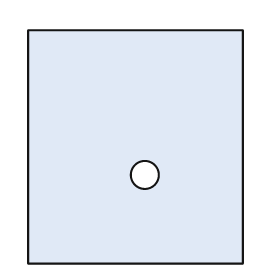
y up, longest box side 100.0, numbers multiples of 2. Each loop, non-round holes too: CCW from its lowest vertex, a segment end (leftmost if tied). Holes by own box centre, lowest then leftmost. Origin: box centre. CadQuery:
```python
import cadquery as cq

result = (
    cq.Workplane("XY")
    .moveTo(-46.0, -50.0)
    .lineTo(46.0, -50.0)
    .lineTo(46.0, 50.0)
    .lineTo(-46.0, 50.0)
    .close()
    .moveTo(4.0, -12.0)
    .circle(6.0)
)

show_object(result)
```